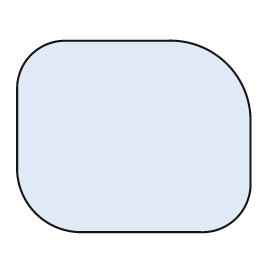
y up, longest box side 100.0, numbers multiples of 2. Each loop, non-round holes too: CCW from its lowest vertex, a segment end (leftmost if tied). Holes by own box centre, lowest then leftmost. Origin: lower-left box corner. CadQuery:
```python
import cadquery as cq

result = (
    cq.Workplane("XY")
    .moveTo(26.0, 0.0)
    .lineTo(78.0, 0.0)
    .threePointArc((94.0, 6.0), (100.0, 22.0))
    .lineTo(100.0, 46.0)
    .threePointArc((90.0, 72.0), (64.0, 82.0))
    .lineTo(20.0, 82.0)
    .threePointArc((6.0, 76.0), (0.0, 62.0))
    .lineTo(0.0, 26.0)
    .threePointArc((8.0, 8.0), (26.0, 0.0))
    .close()
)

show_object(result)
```